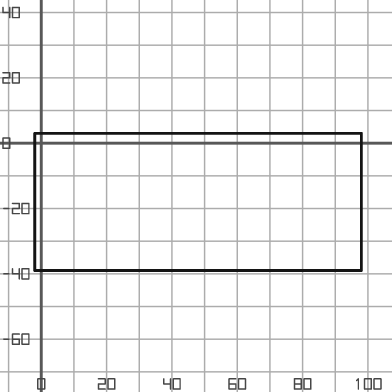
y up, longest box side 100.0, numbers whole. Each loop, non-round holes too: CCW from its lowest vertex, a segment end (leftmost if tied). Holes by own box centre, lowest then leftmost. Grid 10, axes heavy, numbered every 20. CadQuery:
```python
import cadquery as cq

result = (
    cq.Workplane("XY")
    .moveTo(-2.0, -39.0)
    .lineTo(98.0, -39.0)
    .lineTo(98.0, 3.0)
    .lineTo(-2.0, 3.0)
    .close()
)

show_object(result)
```